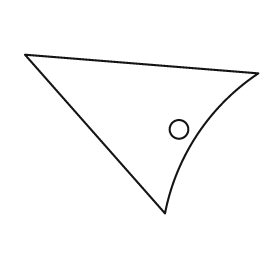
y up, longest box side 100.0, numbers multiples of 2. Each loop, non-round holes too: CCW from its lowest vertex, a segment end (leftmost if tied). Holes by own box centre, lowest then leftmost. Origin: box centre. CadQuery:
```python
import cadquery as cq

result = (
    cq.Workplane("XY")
    .moveTo(10.0, -34.0)
    .threePointArc((24.0, 0.0), (50.0, 26.0))
    .lineTo(-50.0, 34.0)
    .close()
    .moveTo(16.0, 2.0)
    .circle(4.0)
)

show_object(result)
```